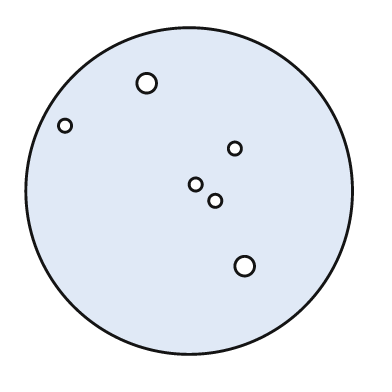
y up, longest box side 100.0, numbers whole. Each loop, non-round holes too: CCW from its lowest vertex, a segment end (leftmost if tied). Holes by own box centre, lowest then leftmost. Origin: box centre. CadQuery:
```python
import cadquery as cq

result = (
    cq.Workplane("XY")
    .moveTo(0.0, 0.0)
    .circle(50.0)
    .moveTo(17.0, -23.0)
    .circle(3.0)
    .moveTo(8.0, -3.0)
    .circle(2.0)
    .moveTo(2.0, 2.0)
    .circle(2.0)
    .moveTo(14.0, 13.0)
    .circle(2.0)
    .moveTo(-38.0, 20.0)
    .circle(2.0)
    .moveTo(-13.0, 33.0)
    .circle(3.0)
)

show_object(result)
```